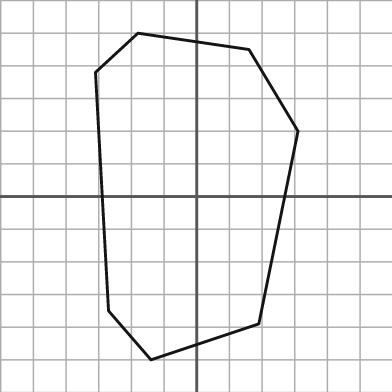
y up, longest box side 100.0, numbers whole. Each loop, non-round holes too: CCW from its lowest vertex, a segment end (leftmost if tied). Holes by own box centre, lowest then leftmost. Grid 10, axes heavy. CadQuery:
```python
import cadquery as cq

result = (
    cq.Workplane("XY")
    .moveTo(-14.0, -50.0)
    .lineTo(19.0, -39.0)
    .lineTo(31.0, 20.0)
    .lineTo(16.0, 45.0)
    .lineTo(-18.0, 50.0)
    .lineTo(-31.0, 38.0)
    .lineTo(-27.0, -35.0)
    .close()
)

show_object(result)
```